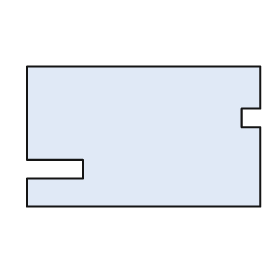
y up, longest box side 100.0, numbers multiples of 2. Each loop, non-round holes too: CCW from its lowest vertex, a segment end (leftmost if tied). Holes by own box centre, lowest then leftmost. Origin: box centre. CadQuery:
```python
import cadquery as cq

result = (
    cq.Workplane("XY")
    .moveTo(-50.0, -30.0)
    .lineTo(50.0, -30.0)
    .lineTo(50.0, 4.0)
    .lineTo(42.0, 4.0)
    .lineTo(42.0, 12.0)
    .lineTo(50.0, 12.0)
    .lineTo(50.0, 30.0)
    .lineTo(-50.0, 30.0)
    .lineTo(-50.0, -10.0)
    .lineTo(-26.0, -10.0)
    .lineTo(-26.0, -18.0)
    .lineTo(-50.0, -18.0)
    .close()
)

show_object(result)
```